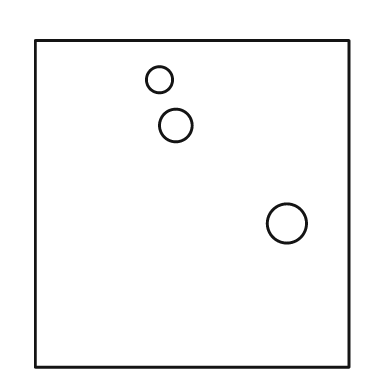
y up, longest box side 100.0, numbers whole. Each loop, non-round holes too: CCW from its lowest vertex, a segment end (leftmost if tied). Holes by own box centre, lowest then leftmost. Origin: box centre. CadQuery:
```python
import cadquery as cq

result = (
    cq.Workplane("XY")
    .moveTo(-48.0, -50.0)
    .lineTo(48.0, -50.0)
    .lineTo(48.0, 50.0)
    .lineTo(-48.0, 50.0)
    .close()
    .moveTo(29.0, -6.0)
    .circle(6.0)
    .moveTo(-5.0, 24.0)
    .circle(5.0)
    .moveTo(-10.0, 38.0)
    .circle(4.0)
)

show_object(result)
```